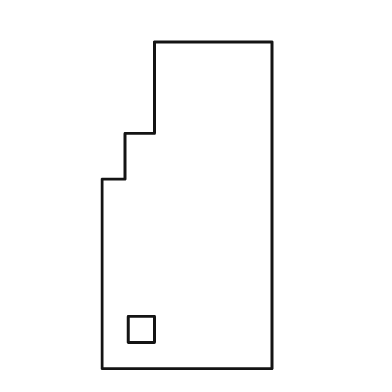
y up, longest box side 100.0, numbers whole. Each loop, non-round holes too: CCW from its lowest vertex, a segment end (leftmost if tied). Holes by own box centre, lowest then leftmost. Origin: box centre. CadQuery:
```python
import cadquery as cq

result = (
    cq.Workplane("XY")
    .moveTo(-26.0, -50.0)
    .lineTo(26.0, -50.0)
    .lineTo(26.0, 50.0)
    .lineTo(-10.0, 50.0)
    .lineTo(-10.0, 22.0)
    .lineTo(-19.0, 22.0)
    .lineTo(-19.0, 8.0)
    .lineTo(-26.0, 8.0)
    .close()
    .moveTo(-18.0, -42.0)
    .lineTo(-10.0, -42.0)
    .lineTo(-10.0, -34.0)
    .lineTo(-18.0, -34.0)
    .close()
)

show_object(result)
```